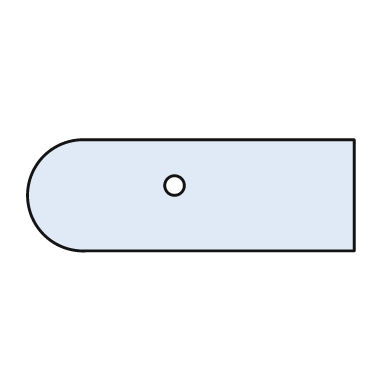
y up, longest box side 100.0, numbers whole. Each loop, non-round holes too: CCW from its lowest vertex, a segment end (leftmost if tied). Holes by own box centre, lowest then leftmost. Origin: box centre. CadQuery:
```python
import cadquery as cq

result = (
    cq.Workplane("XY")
    .moveTo(-32.0, -17.0)
    .lineTo(50.0, -17.0)
    .lineTo(50.0, 17.0)
    .lineTo(-32.0, 17.0)
    .threePointArc((-50.0, 0.0), (-32.0, -17.0))
    .close()
    .moveTo(-5.0, 3.0)
    .circle(3.0)
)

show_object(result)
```